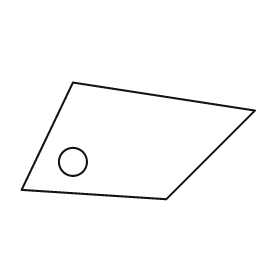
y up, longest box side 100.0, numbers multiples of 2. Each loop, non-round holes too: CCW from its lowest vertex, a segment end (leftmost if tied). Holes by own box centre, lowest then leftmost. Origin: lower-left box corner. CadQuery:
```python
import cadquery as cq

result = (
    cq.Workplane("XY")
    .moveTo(62.0, 0.0)
    .lineTo(100.0, 38.0)
    .lineTo(22.0, 50.0)
    .lineTo(0.0, 4.0)
    .close()
    .moveTo(22.0, 16.0)
    .circle(6.0)
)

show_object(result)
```